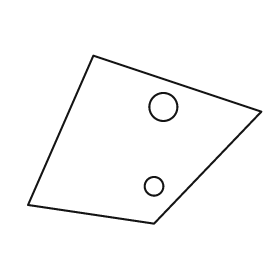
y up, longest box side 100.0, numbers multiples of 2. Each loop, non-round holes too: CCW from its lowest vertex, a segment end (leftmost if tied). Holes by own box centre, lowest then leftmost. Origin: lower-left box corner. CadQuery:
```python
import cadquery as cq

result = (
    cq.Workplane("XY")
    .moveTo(54.0, 0.0)
    .lineTo(100.0, 48.0)
    .lineTo(28.0, 72.0)
    .lineTo(0.0, 8.0)
    .close()
    .moveTo(54.0, 16.0)
    .circle(4.0)
    .moveTo(58.0, 50.0)
    .circle(6.0)
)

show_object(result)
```